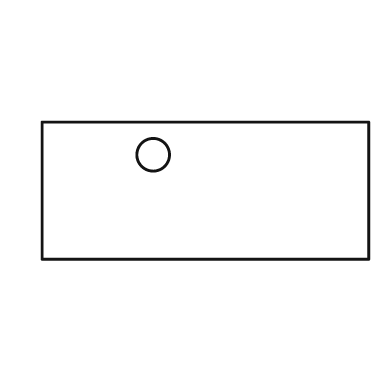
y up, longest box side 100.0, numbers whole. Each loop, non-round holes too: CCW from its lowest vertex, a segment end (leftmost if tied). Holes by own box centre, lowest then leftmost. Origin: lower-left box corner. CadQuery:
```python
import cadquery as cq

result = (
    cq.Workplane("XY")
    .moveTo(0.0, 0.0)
    .lineTo(100.0, 0.0)
    .lineTo(100.0, 42.0)
    .lineTo(0.0, 42.0)
    .close()
    .moveTo(34.0, 32.0)
    .circle(5.0)
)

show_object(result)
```